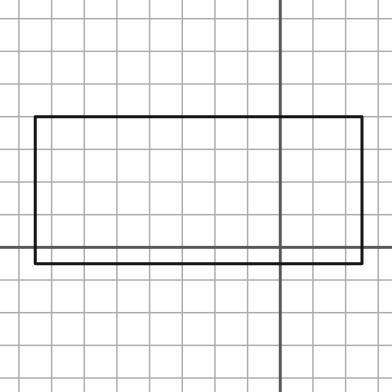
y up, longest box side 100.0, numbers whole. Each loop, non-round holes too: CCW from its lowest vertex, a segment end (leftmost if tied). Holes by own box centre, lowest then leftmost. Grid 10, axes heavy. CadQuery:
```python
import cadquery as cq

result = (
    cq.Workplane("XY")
    .moveTo(-75.0, -5.0)
    .lineTo(25.0, -5.0)
    .lineTo(25.0, 40.0)
    .lineTo(-75.0, 40.0)
    .close()
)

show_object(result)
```